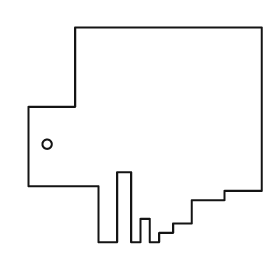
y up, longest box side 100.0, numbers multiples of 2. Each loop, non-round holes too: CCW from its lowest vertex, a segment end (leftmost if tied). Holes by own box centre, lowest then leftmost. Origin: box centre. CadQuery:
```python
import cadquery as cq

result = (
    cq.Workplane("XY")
    .moveTo(-20.0, -46.0)
    .lineTo(-12.0, -46.0)
    .lineTo(-12.0, -16.0)
    .lineTo(-6.0, -16.0)
    .lineTo(-6.0, -46.0)
    .lineTo(-2.0, -46.0)
    .lineTo(-2.0, -36.0)
    .lineTo(2.0, -36.0)
    .lineTo(2.0, -46.0)
    .lineTo(6.0, -46.0)
    .lineTo(6.0, -42.0)
    .lineTo(12.0, -42.0)
    .lineTo(12.0, -38.0)
    .lineTo(20.0, -38.0)
    .lineTo(20.0, -28.0)
    .lineTo(34.0, -28.0)
    .lineTo(34.0, -24.0)
    .lineTo(50.0, -24.0)
    .lineTo(50.0, 46.0)
    .lineTo(-30.0, 46.0)
    .lineTo(-30.0, 12.0)
    .lineTo(-50.0, 12.0)
    .lineTo(-50.0, -22.0)
    .lineTo(-20.0, -22.0)
    .close()
    .moveTo(-42.0, -4.0)
    .circle(2.0)
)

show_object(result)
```